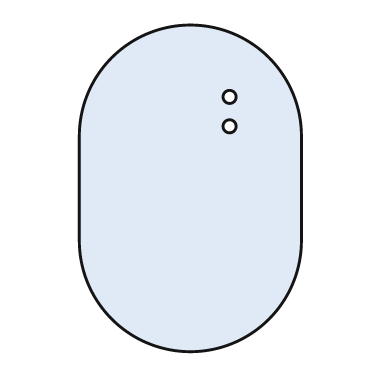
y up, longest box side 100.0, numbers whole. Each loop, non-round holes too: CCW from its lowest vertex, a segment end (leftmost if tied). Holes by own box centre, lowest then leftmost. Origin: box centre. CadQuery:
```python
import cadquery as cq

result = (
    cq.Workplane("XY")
    .moveTo(-34.0, -16.0)
    .threePointArc((0.0, -50.0), (34.0, -16.0))
    .lineTo(34.0, 16.0)
    .threePointArc((0.0, 50.0), (-34.0, 16.0))
    .close()
    .moveTo(12.0, 19.0)
    .circle(2.0)
    .moveTo(12.0, 28.0)
    .circle(2.0)
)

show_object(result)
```